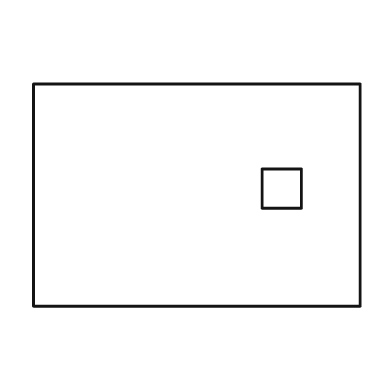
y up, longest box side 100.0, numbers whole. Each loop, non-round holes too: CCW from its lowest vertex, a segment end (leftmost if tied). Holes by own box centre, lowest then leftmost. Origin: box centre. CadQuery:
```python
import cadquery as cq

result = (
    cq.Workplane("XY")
    .moveTo(-50.0, -34.0)
    .lineTo(50.0, -34.0)
    .lineTo(50.0, 34.0)
    .lineTo(-50.0, 34.0)
    .close()
    .moveTo(20.0, -4.0)
    .lineTo(32.0, -4.0)
    .lineTo(32.0, 8.0)
    .lineTo(20.0, 8.0)
    .close()
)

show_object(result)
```